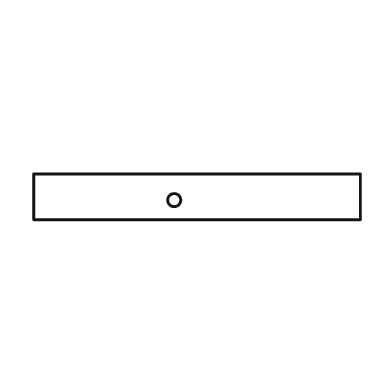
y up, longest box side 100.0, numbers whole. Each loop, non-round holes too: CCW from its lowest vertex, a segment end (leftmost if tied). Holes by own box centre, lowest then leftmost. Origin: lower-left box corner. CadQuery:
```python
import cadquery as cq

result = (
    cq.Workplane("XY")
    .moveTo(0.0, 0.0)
    .lineTo(100.0, 0.0)
    .lineTo(100.0, 14.0)
    .lineTo(0.0, 14.0)
    .close()
    .moveTo(43.0, 6.0)
    .circle(2.0)
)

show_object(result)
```